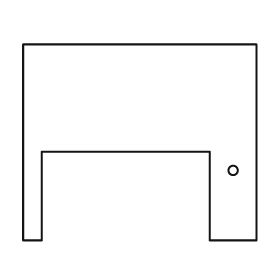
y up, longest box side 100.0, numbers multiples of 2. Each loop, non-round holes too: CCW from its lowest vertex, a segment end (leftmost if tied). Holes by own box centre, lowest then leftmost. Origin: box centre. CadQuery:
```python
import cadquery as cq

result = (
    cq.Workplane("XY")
    .moveTo(-50.0, -42.0)
    .lineTo(-42.0, -42.0)
    .lineTo(-42.0, -4.0)
    .lineTo(30.0, -4.0)
    .lineTo(30.0, -42.0)
    .lineTo(50.0, -42.0)
    .lineTo(50.0, 42.0)
    .lineTo(-50.0, 42.0)
    .close()
    .moveTo(40.0, -12.0)
    .circle(2.0)
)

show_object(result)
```